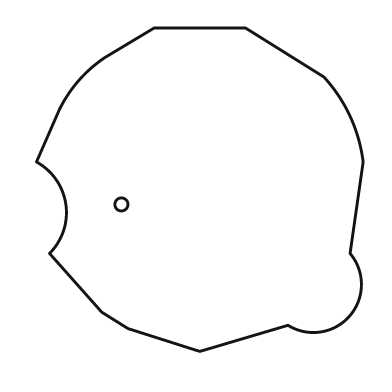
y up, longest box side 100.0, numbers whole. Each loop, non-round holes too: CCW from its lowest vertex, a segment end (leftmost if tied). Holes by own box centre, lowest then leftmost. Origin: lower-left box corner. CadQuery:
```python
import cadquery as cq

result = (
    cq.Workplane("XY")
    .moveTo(50.0, 0.0)
    .lineTo(77.0, 8.0)
    .threePointArc((96.0, 11.0), (96.0, 30.0))
    .lineTo(100.0, 58.0)
    .threePointArc((96.0, 72.0), (88.0, 84.0))
    .lineTo(64.0, 99.0)
    .lineTo(36.0, 99.0)
    .lineTo(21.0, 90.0)
    .threePointArc((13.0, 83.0), (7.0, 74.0))
    .lineTo(0.0, 58.0)
    .threePointArc((9.0, 45.0), (4.0, 30.0))
    .lineTo(20.0, 12.0)
    .lineTo(28.0, 7.0)
    .close()
    .moveTo(26.0, 45.0)
    .circle(2.0)
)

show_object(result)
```